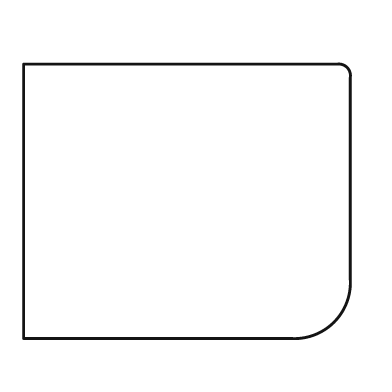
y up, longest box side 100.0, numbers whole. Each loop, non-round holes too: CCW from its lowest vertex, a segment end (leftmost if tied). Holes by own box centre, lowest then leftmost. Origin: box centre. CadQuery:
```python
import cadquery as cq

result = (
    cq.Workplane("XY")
    .moveTo(-50.0, -42.0)
    .lineTo(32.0, -42.0)
    .threePointArc((45.0, -37.0), (50.0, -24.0))
    .lineTo(50.0, 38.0)
    .threePointArc((49.0, 41.0), (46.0, 42.0))
    .lineTo(-50.0, 42.0)
    .close()
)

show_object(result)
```